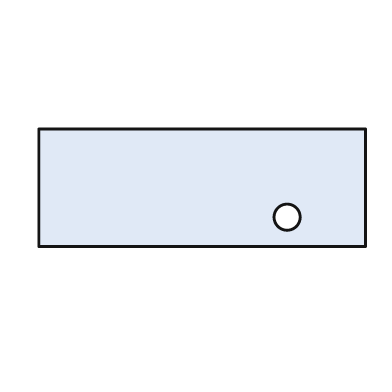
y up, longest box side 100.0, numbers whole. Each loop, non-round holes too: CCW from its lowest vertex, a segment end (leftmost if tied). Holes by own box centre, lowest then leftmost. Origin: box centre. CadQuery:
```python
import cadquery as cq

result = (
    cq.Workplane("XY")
    .moveTo(-50.0, -18.0)
    .lineTo(50.0, -18.0)
    .lineTo(50.0, 18.0)
    .lineTo(-50.0, 18.0)
    .close()
    .moveTo(26.0, -9.0)
    .circle(4.0)
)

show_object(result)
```